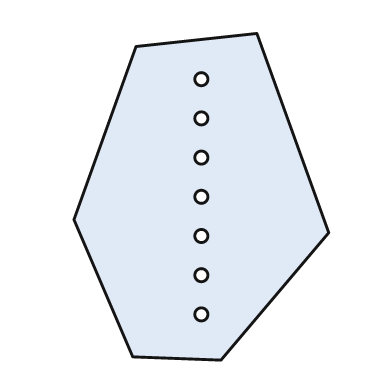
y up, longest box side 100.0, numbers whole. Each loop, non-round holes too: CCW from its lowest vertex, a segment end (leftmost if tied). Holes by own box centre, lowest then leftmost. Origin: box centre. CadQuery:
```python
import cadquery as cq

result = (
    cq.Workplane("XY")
    .moveTo(6.0, -50.0)
    .lineTo(39.0, -11.0)
    .lineTo(17.0, 50.0)
    .lineTo(-20.0, 46.0)
    .lineTo(-39.0, -7.0)
    .lineTo(-21.0, -49.0)
    .close()
    .moveTo(0.0, -36.0)
    .circle(2.0)
    .moveTo(0.0, -24.0)
    .circle(2.0)
    .moveTo(0.0, -12.0)
    .circle(2.0)
    .moveTo(0.0, 0.0)
    .circle(2.0)
    .moveTo(0.0, 12.0)
    .circle(2.0)
    .moveTo(0.0, 24.0)
    .circle(2.0)
    .moveTo(0.0, 36.0)
    .circle(2.0)
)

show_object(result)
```